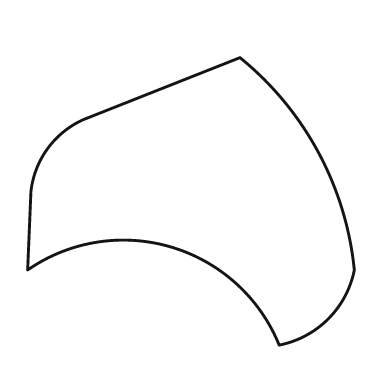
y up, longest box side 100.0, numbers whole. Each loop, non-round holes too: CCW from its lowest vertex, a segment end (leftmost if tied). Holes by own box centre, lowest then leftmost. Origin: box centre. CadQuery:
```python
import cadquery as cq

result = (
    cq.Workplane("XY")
    .moveTo(27.0, -44.0)
    .threePointArc((42.0, -36.0), (50.0, -21.0))
    .threePointArc((39.0, 15.0), (15.0, 44.0))
    .lineTo(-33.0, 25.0)
    .threePointArc((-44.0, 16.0), (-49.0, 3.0))
    .lineTo(-50.0, -21.0)
    .threePointArc((-6.0, -14.0), (27.0, -44.0))
    .close()
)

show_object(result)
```